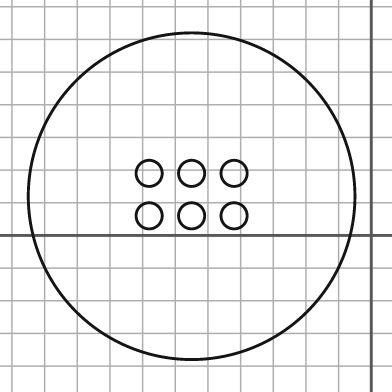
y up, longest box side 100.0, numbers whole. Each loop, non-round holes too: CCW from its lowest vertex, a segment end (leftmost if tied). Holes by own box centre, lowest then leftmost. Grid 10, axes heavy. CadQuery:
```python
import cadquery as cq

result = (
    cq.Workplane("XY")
    .moveTo(-55.0, 12.0)
    .circle(50.0)
    .moveTo(-68.0, 6.0)
    .circle(4.0)
    .moveTo(-55.0, 6.0)
    .circle(4.0)
    .moveTo(-42.0, 6.0)
    .circle(4.0)
    .moveTo(-68.0, 19.0)
    .circle(4.0)
    .moveTo(-55.0, 19.0)
    .circle(4.0)
    .moveTo(-42.0, 19.0)
    .circle(4.0)
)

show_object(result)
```